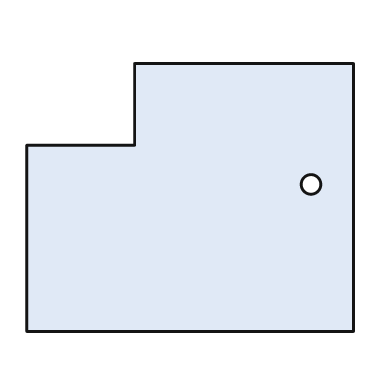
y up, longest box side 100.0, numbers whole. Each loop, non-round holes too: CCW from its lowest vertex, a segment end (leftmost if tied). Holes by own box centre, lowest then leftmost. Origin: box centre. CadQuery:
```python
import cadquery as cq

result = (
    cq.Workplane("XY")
    .moveTo(-50.0, -41.0)
    .lineTo(50.0, -41.0)
    .lineTo(50.0, 41.0)
    .lineTo(-17.0, 41.0)
    .lineTo(-17.0, 16.0)
    .lineTo(-50.0, 16.0)
    .close()
    .moveTo(37.0, 4.0)
    .circle(3.0)
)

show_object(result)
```